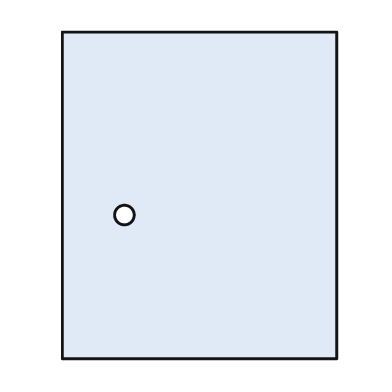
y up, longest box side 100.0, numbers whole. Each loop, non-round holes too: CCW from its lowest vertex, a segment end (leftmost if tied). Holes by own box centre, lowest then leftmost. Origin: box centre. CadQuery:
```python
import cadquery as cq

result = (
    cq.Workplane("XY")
    .moveTo(-42.0, -50.0)
    .lineTo(42.0, -50.0)
    .lineTo(42.0, 50.0)
    .lineTo(-42.0, 50.0)
    .close()
    .moveTo(-23.0, -6.0)
    .circle(3.0)
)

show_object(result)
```